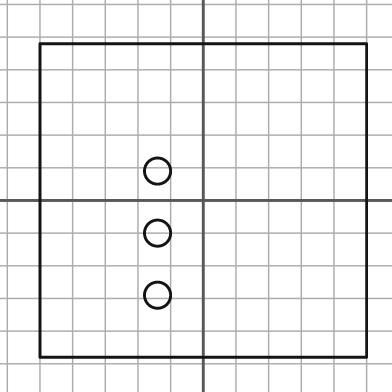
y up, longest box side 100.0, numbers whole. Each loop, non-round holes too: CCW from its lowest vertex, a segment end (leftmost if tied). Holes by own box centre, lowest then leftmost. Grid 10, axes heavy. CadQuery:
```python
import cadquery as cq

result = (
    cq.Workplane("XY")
    .moveTo(-50.0, -48.0)
    .lineTo(50.0, -48.0)
    .lineTo(50.0, 48.0)
    .lineTo(-50.0, 48.0)
    .close()
    .moveTo(-14.0, -29.0)
    .circle(4.0)
    .moveTo(-14.0, -10.0)
    .circle(4.0)
    .moveTo(-14.0, 9.0)
    .circle(4.0)
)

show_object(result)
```